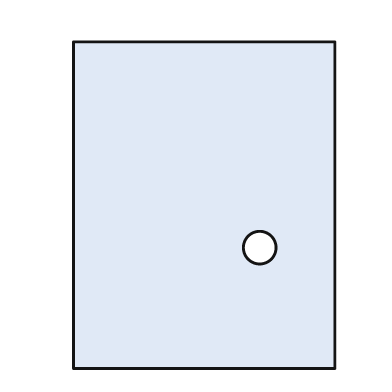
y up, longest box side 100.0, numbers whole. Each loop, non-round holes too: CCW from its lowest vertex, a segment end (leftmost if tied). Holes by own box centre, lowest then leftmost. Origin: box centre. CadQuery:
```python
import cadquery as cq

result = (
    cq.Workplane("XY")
    .moveTo(-40.0, -50.0)
    .lineTo(40.0, -50.0)
    .lineTo(40.0, 50.0)
    .lineTo(-40.0, 50.0)
    .close()
    .moveTo(17.0, -13.0)
    .circle(5.0)
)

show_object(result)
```